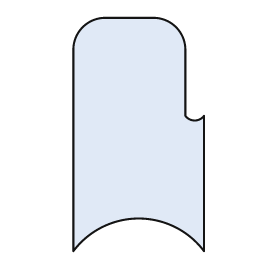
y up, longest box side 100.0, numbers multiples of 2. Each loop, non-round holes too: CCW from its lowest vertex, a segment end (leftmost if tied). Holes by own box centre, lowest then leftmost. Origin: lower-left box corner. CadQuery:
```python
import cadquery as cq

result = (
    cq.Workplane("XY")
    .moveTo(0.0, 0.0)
    .threePointArc((28.0, 14.0), (56.0, 0.0))
    .lineTo(56.0, 58.0)
    .threePointArc((52.0, 56.0), (48.0, 58.0))
    .lineTo(48.0, 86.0)
    .threePointArc((44.0, 96.0), (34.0, 100.0))
    .lineTo(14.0, 100.0)
    .threePointArc((4.0, 96.0), (0.0, 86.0))
    .close()
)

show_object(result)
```